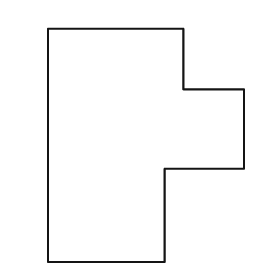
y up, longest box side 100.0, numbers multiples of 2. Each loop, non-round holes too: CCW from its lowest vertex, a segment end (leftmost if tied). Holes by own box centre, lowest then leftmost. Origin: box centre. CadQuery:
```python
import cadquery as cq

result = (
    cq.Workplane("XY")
    .moveTo(-42.0, -50.0)
    .lineTo(8.0, -50.0)
    .lineTo(8.0, -10.0)
    .lineTo(42.0, -10.0)
    .lineTo(42.0, 24.0)
    .lineTo(16.0, 24.0)
    .lineTo(16.0, 50.0)
    .lineTo(-42.0, 50.0)
    .close()
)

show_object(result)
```